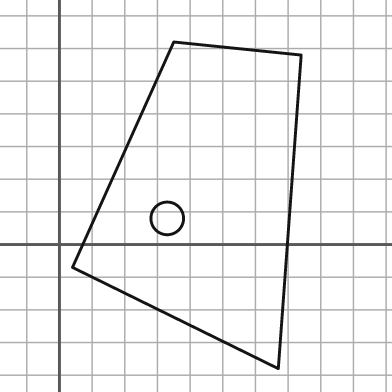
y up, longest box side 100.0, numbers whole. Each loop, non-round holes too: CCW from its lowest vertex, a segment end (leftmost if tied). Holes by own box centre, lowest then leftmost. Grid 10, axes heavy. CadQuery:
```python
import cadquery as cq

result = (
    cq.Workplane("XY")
    .moveTo(67.0, -38.0)
    .lineTo(74.0, 58.0)
    .lineTo(35.0, 62.0)
    .lineTo(4.0, -7.0)
    .close()
    .moveTo(33.0, 8.0)
    .circle(5.0)
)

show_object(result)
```